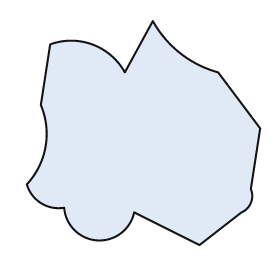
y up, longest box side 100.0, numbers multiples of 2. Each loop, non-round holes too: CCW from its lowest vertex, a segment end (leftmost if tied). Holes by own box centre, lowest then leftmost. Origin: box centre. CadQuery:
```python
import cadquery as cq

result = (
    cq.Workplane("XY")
    .moveTo(24.0, -48.0)
    .lineTo(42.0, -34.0)
    .threePointArc((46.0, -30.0), (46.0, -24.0))
    .lineTo(50.0, 2.0)
    .lineTo(32.0, 26.0)
    .threePointArc((16.0, 34.0), (4.0, 48.0))
    .lineTo(-8.0, 26.0)
    .threePointArc((-22.0, 38.0), (-40.0, 38.0))
    .lineTo(-44.0, 12.0)
    .threePointArc((-42.0, -6.0), (-50.0, -22.0))
    .threePointArc((-44.0, -30.0), (-34.0, -32.0))
    .threePointArc((-20.0, -46.0), (-4.0, -34.0))
    .close()
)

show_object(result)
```